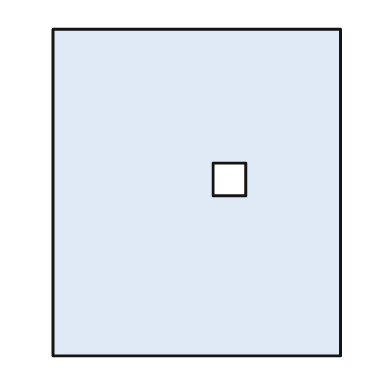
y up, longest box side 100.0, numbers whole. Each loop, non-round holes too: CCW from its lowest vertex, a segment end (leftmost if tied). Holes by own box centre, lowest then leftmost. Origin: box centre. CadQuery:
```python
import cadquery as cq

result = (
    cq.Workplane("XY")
    .moveTo(-44.0, -50.0)
    .lineTo(44.0, -50.0)
    .lineTo(44.0, 50.0)
    .lineTo(-44.0, 50.0)
    .close()
    .moveTo(5.0, -1.0)
    .lineTo(15.0, -1.0)
    .lineTo(15.0, 9.0)
    .lineTo(5.0, 9.0)
    .close()
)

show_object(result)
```